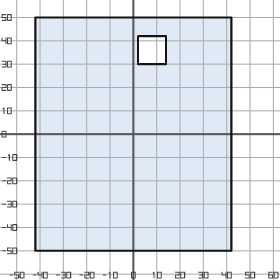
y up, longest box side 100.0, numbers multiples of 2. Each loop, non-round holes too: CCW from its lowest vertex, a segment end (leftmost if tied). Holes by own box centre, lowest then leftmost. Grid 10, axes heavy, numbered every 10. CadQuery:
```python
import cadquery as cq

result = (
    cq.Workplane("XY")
    .moveTo(-42.0, -50.0)
    .lineTo(42.0, -50.0)
    .lineTo(42.0, 50.0)
    .lineTo(-42.0, 50.0)
    .close()
    .moveTo(2.0, 30.0)
    .lineTo(14.0, 30.0)
    .lineTo(14.0, 42.0)
    .lineTo(2.0, 42.0)
    .close()
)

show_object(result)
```